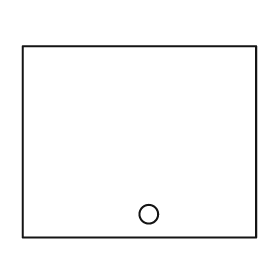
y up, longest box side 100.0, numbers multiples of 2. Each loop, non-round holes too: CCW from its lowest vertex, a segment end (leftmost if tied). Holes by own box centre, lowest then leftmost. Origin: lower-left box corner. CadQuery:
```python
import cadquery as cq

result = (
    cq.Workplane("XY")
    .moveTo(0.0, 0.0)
    .lineTo(100.0, 0.0)
    .lineTo(100.0, 82.0)
    .lineTo(0.0, 82.0)
    .close()
    .moveTo(54.0, 10.0)
    .circle(4.0)
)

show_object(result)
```